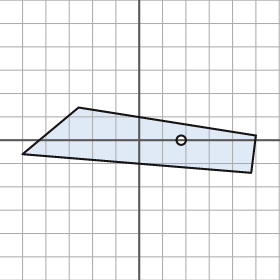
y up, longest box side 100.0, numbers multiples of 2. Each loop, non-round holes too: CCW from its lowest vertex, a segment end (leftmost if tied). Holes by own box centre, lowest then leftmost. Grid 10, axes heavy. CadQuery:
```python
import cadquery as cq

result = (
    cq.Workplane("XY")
    .moveTo(48.0, -14.0)
    .lineTo(50.0, 2.0)
    .lineTo(-26.0, 14.0)
    .lineTo(-50.0, -6.0)
    .close()
    .moveTo(18.0, 0.0)
    .circle(2.0)
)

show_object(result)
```